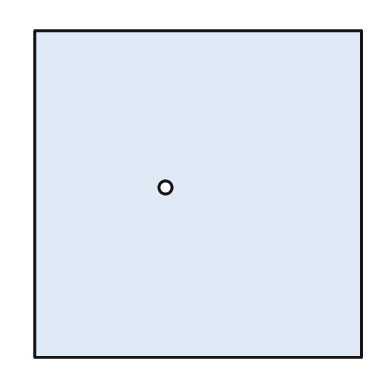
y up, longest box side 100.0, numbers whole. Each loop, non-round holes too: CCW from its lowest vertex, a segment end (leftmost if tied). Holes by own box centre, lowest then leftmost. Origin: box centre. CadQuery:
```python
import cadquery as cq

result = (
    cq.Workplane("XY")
    .moveTo(-50.0, -50.0)
    .lineTo(50.0, -50.0)
    .lineTo(50.0, 50.0)
    .lineTo(-50.0, 50.0)
    .close()
    .moveTo(-10.0, 2.0)
    .circle(2.0)
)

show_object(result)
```